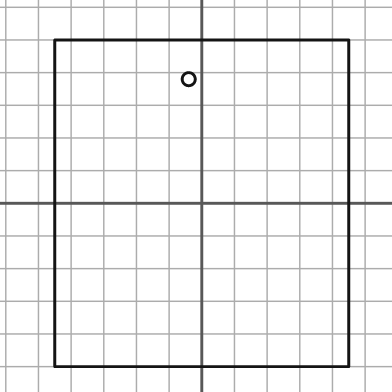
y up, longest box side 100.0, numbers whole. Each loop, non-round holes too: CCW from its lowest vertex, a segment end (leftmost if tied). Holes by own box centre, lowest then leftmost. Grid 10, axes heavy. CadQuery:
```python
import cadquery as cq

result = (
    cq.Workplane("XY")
    .moveTo(-45.0, -50.0)
    .lineTo(45.0, -50.0)
    .lineTo(45.0, 50.0)
    .lineTo(-45.0, 50.0)
    .close()
    .moveTo(-4.0, 38.0)
    .circle(2.0)
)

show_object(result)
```